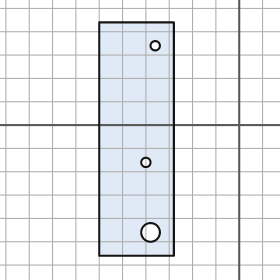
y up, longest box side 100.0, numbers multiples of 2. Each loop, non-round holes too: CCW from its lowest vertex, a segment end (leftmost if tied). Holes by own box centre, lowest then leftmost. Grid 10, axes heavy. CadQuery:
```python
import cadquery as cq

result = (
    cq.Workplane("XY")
    .moveTo(-60.0, -56.0)
    .lineTo(-28.0, -56.0)
    .lineTo(-28.0, 44.0)
    .lineTo(-60.0, 44.0)
    .close()
    .moveTo(-38.0, -46.0)
    .circle(4.0)
    .moveTo(-40.0, -16.0)
    .circle(2.0)
    .moveTo(-36.0, 34.0)
    .circle(2.0)
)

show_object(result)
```